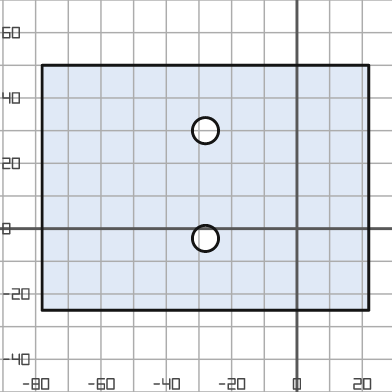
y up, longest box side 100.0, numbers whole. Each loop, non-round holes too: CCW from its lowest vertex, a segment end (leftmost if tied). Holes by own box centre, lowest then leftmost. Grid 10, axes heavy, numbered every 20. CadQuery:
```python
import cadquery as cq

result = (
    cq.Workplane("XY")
    .moveTo(-78.0, -25.0)
    .lineTo(22.0, -25.0)
    .lineTo(22.0, 50.0)
    .lineTo(-78.0, 50.0)
    .close()
    .moveTo(-28.0, -3.0)
    .circle(4.0)
    .moveTo(-28.0, 30.0)
    .circle(4.0)
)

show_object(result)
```